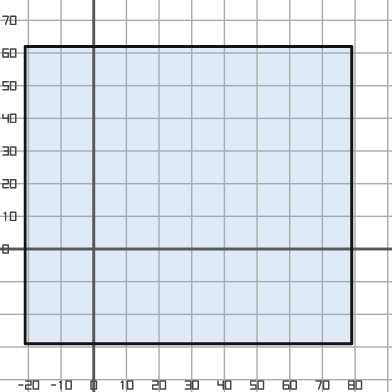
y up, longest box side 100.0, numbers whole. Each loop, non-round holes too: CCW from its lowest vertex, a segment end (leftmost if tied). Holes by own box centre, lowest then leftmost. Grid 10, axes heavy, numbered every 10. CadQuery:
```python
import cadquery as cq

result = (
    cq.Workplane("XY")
    .moveTo(-21.0, -29.0)
    .lineTo(79.0, -29.0)
    .lineTo(79.0, 62.0)
    .lineTo(-21.0, 62.0)
    .close()
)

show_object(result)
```